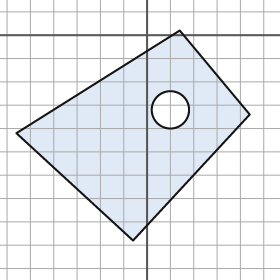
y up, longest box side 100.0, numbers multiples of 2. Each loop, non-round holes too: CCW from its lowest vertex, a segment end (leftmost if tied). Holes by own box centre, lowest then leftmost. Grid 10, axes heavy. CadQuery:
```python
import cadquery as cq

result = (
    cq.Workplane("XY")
    .moveTo(-6.0, -88.0)
    .lineTo(44.0, -34.0)
    .lineTo(14.0, 2.0)
    .lineTo(-56.0, -42.0)
    .close()
    .moveTo(10.0, -32.0)
    .circle(8.0)
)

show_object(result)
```